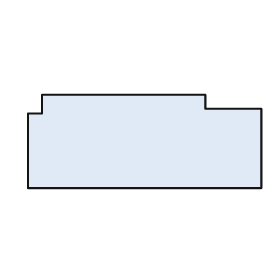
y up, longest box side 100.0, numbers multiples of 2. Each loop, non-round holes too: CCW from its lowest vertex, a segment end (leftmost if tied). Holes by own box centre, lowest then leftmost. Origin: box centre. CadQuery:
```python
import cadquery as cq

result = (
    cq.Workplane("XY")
    .moveTo(-50.0, -20.0)
    .lineTo(50.0, -20.0)
    .lineTo(50.0, 14.0)
    .lineTo(26.0, 14.0)
    .lineTo(26.0, 20.0)
    .lineTo(-44.0, 20.0)
    .lineTo(-44.0, 12.0)
    .lineTo(-50.0, 12.0)
    .close()
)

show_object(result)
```